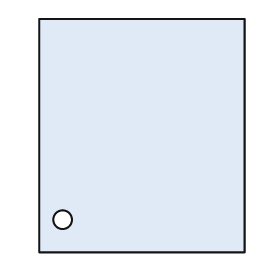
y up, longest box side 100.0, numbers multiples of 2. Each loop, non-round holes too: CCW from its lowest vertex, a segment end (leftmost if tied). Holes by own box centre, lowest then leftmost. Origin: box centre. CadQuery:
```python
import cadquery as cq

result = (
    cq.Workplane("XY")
    .moveTo(-44.0, -50.0)
    .lineTo(44.0, -50.0)
    .lineTo(44.0, 50.0)
    .lineTo(-44.0, 50.0)
    .close()
    .moveTo(-34.0, -36.0)
    .circle(4.0)
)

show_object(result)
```